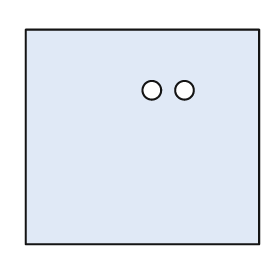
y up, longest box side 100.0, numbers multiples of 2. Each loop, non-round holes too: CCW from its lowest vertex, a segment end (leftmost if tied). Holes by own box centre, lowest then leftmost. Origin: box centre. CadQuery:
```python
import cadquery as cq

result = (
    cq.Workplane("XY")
    .moveTo(-50.0, -46.0)
    .lineTo(50.0, -46.0)
    .lineTo(50.0, 46.0)
    .lineTo(-50.0, 46.0)
    .close()
    .moveTo(4.0, 20.0)
    .circle(4.0)
    .moveTo(18.0, 20.0)
    .circle(4.0)
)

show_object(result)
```